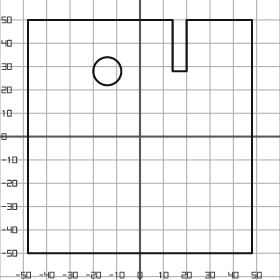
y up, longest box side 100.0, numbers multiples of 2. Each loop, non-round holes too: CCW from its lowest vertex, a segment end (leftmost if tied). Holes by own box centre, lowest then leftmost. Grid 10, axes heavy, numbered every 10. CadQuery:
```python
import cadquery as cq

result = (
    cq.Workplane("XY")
    .moveTo(-48.0, -50.0)
    .lineTo(48.0, -50.0)
    .lineTo(48.0, 50.0)
    .lineTo(20.0, 50.0)
    .lineTo(20.0, 28.0)
    .lineTo(14.0, 28.0)
    .lineTo(14.0, 50.0)
    .lineTo(-48.0, 50.0)
    .close()
    .moveTo(-14.0, 28.0)
    .circle(6.0)
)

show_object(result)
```